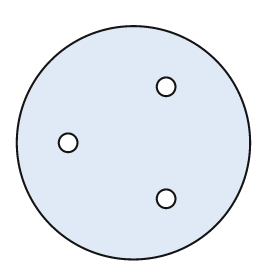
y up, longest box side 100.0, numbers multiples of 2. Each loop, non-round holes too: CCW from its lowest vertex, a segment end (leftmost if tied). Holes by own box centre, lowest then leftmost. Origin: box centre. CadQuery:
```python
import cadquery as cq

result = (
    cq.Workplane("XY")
    .moveTo(0.0, 0.0)
    .circle(50.0)
    .moveTo(14.0, -24.0)
    .circle(4.0)
    .moveTo(-28.0, 0.0)
    .circle(4.0)
    .moveTo(14.0, 24.0)
    .circle(4.0)
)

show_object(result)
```